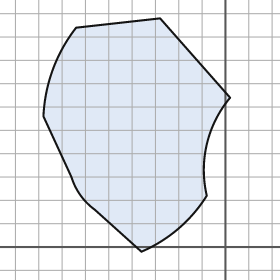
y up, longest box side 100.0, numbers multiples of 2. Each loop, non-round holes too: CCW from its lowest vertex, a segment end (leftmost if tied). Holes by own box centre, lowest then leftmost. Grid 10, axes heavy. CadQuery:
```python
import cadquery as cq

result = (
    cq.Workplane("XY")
    .moveTo(-36.0, -2.0)
    .threePointArc((-20.0, 8.0), (-8.0, 22.0))
    .threePointArc((-8.0, 44.0), (2.0, 64.0))
    .lineTo(-28.0, 98.0)
    .lineTo(-64.0, 94.0)
    .threePointArc((-74.0, 76.0), (-78.0, 56.0))
    .lineTo(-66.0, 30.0)
    .threePointArc((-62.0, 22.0), (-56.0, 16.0))
    .close()
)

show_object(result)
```